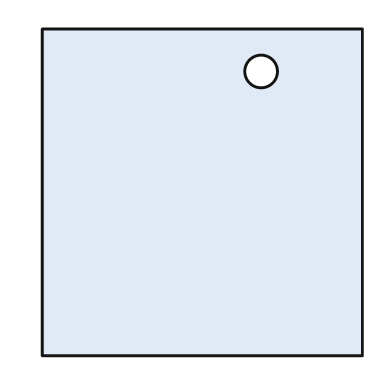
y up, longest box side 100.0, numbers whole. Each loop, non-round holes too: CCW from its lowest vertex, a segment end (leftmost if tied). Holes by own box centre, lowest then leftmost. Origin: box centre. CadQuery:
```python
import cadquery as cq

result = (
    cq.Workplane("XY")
    .moveTo(-49.0, -50.0)
    .lineTo(49.0, -50.0)
    .lineTo(49.0, 50.0)
    .lineTo(-49.0, 50.0)
    .close()
    .moveTo(18.0, 37.0)
    .circle(5.0)
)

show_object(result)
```